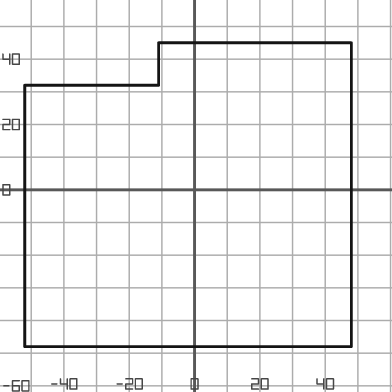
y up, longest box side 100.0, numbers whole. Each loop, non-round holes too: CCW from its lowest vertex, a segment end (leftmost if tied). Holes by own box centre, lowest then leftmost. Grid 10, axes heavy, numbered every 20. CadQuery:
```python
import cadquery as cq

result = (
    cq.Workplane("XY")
    .moveTo(-52.0, -48.0)
    .lineTo(48.0, -48.0)
    .lineTo(48.0, 45.0)
    .lineTo(-11.0, 45.0)
    .lineTo(-11.0, 32.0)
    .lineTo(-52.0, 32.0)
    .close()
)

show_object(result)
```